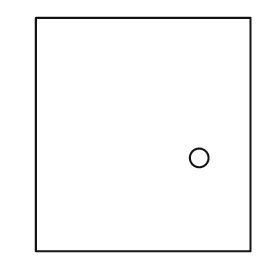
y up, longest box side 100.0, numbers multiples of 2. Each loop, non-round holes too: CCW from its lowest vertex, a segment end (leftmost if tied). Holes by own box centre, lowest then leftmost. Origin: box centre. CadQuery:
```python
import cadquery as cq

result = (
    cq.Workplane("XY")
    .moveTo(-46.0, -50.0)
    .lineTo(46.0, -50.0)
    .lineTo(46.0, 50.0)
    .lineTo(-46.0, 50.0)
    .close()
    .moveTo(24.0, -10.0)
    .circle(4.0)
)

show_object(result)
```